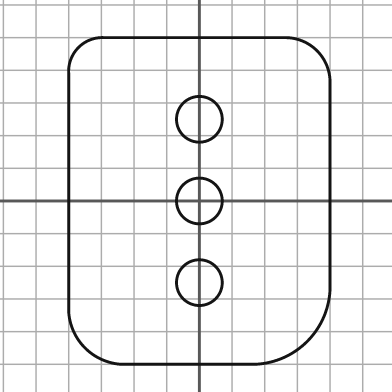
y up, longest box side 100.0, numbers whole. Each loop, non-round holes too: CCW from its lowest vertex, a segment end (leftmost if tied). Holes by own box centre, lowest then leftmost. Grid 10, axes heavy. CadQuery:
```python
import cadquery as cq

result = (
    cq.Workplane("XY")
    .moveTo(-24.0, -50.0)
    .lineTo(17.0, -50.0)
    .threePointArc((33.0, -43.0), (40.0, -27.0))
    .lineTo(40.0, 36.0)
    .threePointArc((36.0, 46.0), (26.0, 50.0))
    .lineTo(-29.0, 50.0)
    .threePointArc((-37.0, 47.0), (-40.0, 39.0))
    .lineTo(-40.0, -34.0)
    .threePointArc((-35.0, -45.0), (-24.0, -50.0))
    .close()
    .moveTo(0.0, -25.0)
    .circle(7.0)
    .moveTo(0.0, 0.0)
    .circle(7.0)
    .moveTo(0.0, 25.0)
    .circle(7.0)
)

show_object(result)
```